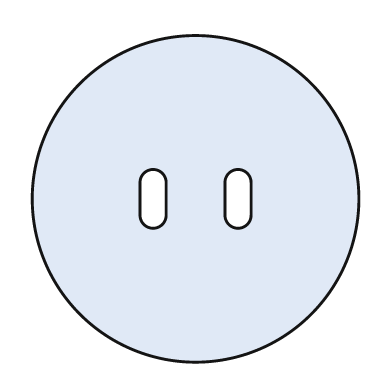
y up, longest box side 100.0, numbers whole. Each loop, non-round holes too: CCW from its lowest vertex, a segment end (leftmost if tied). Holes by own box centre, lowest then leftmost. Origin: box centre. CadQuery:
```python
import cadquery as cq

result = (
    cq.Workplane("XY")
    .moveTo(0.0, 0.0)
    .circle(50.0)
    .moveTo(-17.0, -5.0)
    .threePointArc((-13.0, -9.0), (-9.0, -5.0))
    .lineTo(-9.0, 5.0)
    .threePointArc((-13.0, 9.0), (-17.0, 5.0))
    .close()
    .moveTo(9.0, -5.0)
    .threePointArc((13.0, -9.0), (17.0, -5.0))
    .lineTo(17.0, 5.0)
    .threePointArc((13.0, 9.0), (9.0, 5.0))
    .close()
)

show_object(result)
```